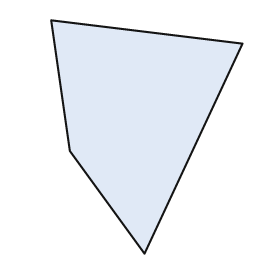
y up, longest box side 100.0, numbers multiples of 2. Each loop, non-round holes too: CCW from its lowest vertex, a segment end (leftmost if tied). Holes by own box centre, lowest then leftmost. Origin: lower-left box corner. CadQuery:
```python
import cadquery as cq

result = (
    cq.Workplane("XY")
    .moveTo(40.0, 0.0)
    .lineTo(82.0, 90.0)
    .lineTo(0.0, 100.0)
    .lineTo(8.0, 44.0)
    .close()
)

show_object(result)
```